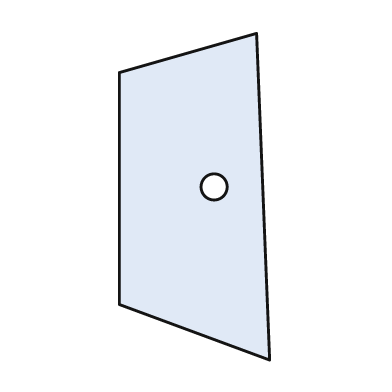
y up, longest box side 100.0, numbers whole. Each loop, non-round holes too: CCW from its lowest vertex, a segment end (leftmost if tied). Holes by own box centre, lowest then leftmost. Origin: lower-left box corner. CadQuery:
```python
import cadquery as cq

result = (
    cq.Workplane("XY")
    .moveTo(46.0, 0.0)
    .lineTo(42.0, 100.0)
    .lineTo(0.0, 88.0)
    .lineTo(0.0, 17.0)
    .close()
    .moveTo(29.0, 53.0)
    .circle(4.0)
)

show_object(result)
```